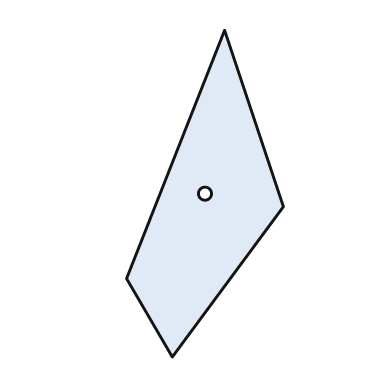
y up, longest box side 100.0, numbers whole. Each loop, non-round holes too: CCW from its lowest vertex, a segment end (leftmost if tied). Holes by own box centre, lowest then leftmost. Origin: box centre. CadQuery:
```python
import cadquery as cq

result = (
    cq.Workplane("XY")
    .moveTo(-10.0, -50.0)
    .lineTo(24.0, -4.0)
    .lineTo(6.0, 50.0)
    .lineTo(-24.0, -26.0)
    .close()
    .moveTo(0.0, 0.0)
    .circle(2.0)
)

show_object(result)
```